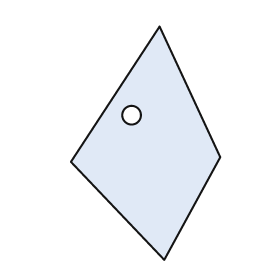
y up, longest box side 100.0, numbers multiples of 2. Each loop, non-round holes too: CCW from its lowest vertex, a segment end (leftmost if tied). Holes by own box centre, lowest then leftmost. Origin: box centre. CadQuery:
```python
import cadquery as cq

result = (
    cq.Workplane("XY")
    .moveTo(8.0, -50.0)
    .lineTo(32.0, -6.0)
    .lineTo(6.0, 50.0)
    .lineTo(-32.0, -8.0)
    .close()
    .moveTo(-6.0, 12.0)
    .circle(4.0)
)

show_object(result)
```